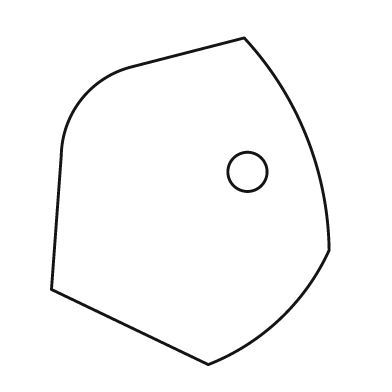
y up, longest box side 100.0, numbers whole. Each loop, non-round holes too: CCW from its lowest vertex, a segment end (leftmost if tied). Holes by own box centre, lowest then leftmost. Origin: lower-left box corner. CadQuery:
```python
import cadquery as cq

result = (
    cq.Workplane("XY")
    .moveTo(48.0, 0.0)
    .threePointArc((70.0, 14.0), (85.0, 35.0))
    .threePointArc((78.0, 70.0), (59.0, 100.0))
    .lineTo(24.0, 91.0)
    .threePointArc((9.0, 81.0), (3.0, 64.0))
    .lineTo(0.0, 23.0)
    .close()
    .moveTo(60.0, 59.0)
    .circle(6.0)
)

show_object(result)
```